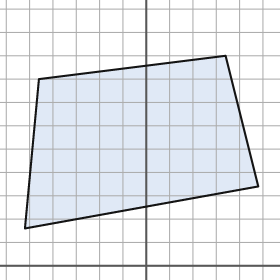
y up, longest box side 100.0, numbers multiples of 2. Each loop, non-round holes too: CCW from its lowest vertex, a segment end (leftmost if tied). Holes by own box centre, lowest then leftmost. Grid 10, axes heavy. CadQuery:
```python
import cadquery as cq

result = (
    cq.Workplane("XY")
    .moveTo(-52.0, 16.0)
    .lineTo(48.0, 34.0)
    .lineTo(34.0, 90.0)
    .lineTo(-46.0, 80.0)
    .close()
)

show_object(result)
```